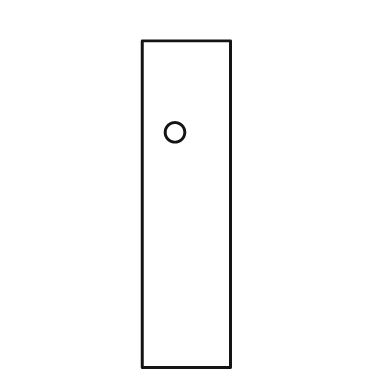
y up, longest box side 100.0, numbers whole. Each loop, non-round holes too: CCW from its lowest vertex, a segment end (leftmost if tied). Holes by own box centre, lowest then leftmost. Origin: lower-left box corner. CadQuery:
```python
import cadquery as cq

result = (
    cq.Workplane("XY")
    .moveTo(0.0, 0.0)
    .lineTo(27.0, 0.0)
    .lineTo(27.0, 100.0)
    .lineTo(0.0, 100.0)
    .close()
    .moveTo(10.0, 72.0)
    .circle(3.0)
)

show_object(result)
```